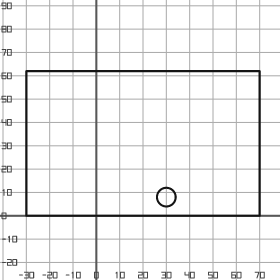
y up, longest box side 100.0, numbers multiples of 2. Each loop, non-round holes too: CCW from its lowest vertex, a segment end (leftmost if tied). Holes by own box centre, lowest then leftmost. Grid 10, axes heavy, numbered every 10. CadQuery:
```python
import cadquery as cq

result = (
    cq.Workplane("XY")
    .moveTo(-30.0, 0.0)
    .lineTo(70.0, 0.0)
    .lineTo(70.0, 62.0)
    .lineTo(-30.0, 62.0)
    .close()
    .moveTo(30.0, 8.0)
    .circle(4.0)
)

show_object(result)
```